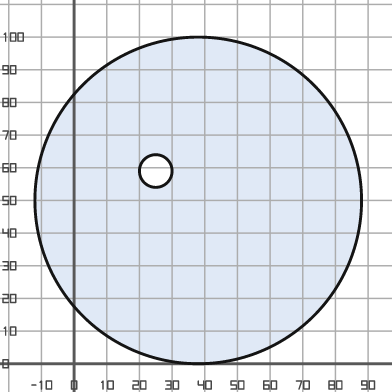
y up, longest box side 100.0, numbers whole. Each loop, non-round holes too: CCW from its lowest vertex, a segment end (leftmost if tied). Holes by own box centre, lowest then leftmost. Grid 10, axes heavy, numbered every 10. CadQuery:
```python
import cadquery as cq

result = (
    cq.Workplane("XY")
    .moveTo(38.0, 50.0)
    .circle(50.0)
    .moveTo(25.0, 59.0)
    .circle(5.0)
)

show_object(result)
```